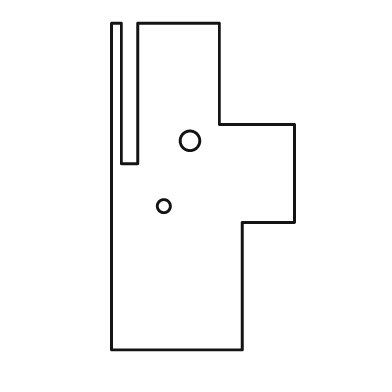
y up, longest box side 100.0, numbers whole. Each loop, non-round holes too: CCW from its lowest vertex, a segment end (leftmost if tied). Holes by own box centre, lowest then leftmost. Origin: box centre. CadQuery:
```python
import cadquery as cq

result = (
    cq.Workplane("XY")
    .moveTo(-28.0, -50.0)
    .lineTo(12.0, -50.0)
    .lineTo(12.0, -11.0)
    .lineTo(28.0, -11.0)
    .lineTo(28.0, 19.0)
    .lineTo(5.0, 19.0)
    .lineTo(5.0, 50.0)
    .lineTo(-20.0, 50.0)
    .lineTo(-20.0, 7.0)
    .lineTo(-25.0, 7.0)
    .lineTo(-25.0, 50.0)
    .lineTo(-28.0, 50.0)
    .close()
    .moveTo(-12.0, -6.0)
    .circle(2.0)
    .moveTo(-4.0, 14.0)
    .circle(3.0)
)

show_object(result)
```